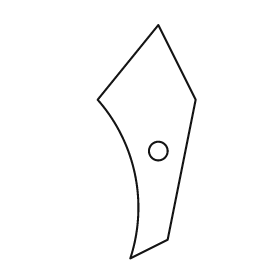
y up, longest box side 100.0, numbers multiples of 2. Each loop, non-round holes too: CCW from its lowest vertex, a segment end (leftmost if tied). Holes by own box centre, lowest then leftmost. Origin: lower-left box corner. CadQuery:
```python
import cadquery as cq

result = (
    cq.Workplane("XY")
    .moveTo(14.0, 0.0)
    .lineTo(30.0, 8.0)
    .lineTo(42.0, 68.0)
    .lineTo(26.0, 100.0)
    .lineTo(0.0, 68.0)
    .threePointArc((16.0, 36.0), (14.0, 0.0))
    .close()
    .moveTo(26.0, 46.0)
    .circle(4.0)
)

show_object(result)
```